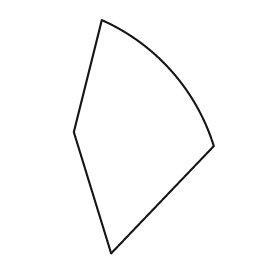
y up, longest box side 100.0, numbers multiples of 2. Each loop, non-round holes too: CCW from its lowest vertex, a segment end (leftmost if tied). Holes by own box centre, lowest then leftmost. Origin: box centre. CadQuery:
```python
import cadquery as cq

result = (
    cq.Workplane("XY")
    .moveTo(-14.0, -50.0)
    .lineTo(30.0, -4.0)
    .threePointArc((12.0, 28.0), (-18.0, 50.0))
    .lineTo(-30.0, 2.0)
    .close()
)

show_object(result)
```